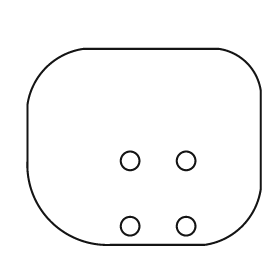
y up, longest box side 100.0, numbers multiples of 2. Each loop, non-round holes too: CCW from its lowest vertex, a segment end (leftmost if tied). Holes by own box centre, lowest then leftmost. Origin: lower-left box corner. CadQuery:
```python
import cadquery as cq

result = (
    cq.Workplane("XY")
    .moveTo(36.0, 0.0)
    .lineTo(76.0, 0.0)
    .threePointArc((92.0, 8.0), (100.0, 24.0))
    .lineTo(100.0, 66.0)
    .threePointArc((94.0, 78.0), (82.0, 84.0))
    .lineTo(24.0, 84.0)
    .threePointArc((8.0, 76.0), (0.0, 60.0))
    .lineTo(0.0, 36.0)
    .threePointArc((10.0, 10.0), (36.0, 0.0))
    .close()
    .moveTo(44.0, 8.0)
    .circle(4.0)
    .moveTo(68.0, 8.0)
    .circle(4.0)
    .moveTo(44.0, 36.0)
    .circle(4.0)
    .moveTo(68.0, 36.0)
    .circle(4.0)
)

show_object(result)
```